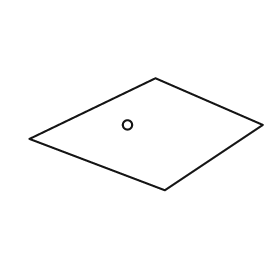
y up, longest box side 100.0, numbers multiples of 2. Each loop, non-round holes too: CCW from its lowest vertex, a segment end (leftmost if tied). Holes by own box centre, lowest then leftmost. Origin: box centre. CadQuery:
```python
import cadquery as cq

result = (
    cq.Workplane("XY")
    .moveTo(8.0, -24.0)
    .lineTo(50.0, 4.0)
    .lineTo(4.0, 24.0)
    .lineTo(-50.0, -2.0)
    .close()
    .moveTo(-8.0, 4.0)
    .circle(2.0)
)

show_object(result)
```